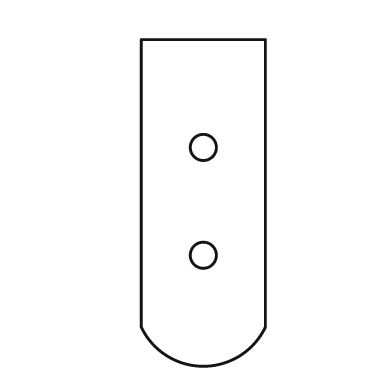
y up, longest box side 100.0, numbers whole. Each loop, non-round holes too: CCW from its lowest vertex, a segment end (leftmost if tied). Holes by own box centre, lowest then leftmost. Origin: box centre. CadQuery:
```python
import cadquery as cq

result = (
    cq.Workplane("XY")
    .moveTo(-19.0, -38.0)
    .threePointArc((0.0, -50.0), (19.0, -38.0))
    .lineTo(19.0, 50.0)
    .lineTo(-19.0, 50.0)
    .close()
    .moveTo(0.0, -16.0)
    .circle(4.0)
    .moveTo(0.0, 17.0)
    .circle(4.0)
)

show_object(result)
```